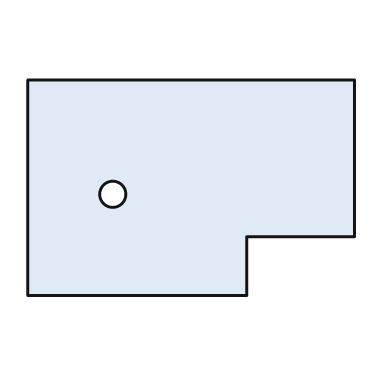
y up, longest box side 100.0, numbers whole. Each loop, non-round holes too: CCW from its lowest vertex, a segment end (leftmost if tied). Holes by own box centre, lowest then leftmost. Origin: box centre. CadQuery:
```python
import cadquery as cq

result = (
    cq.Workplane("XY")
    .moveTo(-50.0, -33.0)
    .lineTo(17.0, -33.0)
    .lineTo(17.0, -15.0)
    .lineTo(50.0, -15.0)
    .lineTo(50.0, 33.0)
    .lineTo(-50.0, 33.0)
    .close()
    .moveTo(-24.0, -2.0)
    .circle(4.0)
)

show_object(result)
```